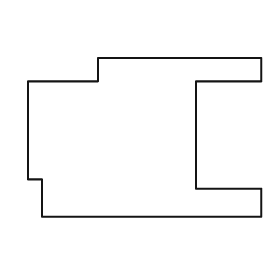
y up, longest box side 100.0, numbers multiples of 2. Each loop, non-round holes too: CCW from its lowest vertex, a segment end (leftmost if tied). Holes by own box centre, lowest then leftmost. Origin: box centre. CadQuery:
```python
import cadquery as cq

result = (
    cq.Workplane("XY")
    .moveTo(-44.0, -34.0)
    .lineTo(50.0, -34.0)
    .lineTo(50.0, -22.0)
    .lineTo(22.0, -22.0)
    .lineTo(22.0, 24.0)
    .lineTo(50.0, 24.0)
    .lineTo(50.0, 34.0)
    .lineTo(-20.0, 34.0)
    .lineTo(-20.0, 24.0)
    .lineTo(-50.0, 24.0)
    .lineTo(-50.0, -18.0)
    .lineTo(-44.0, -18.0)
    .close()
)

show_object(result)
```